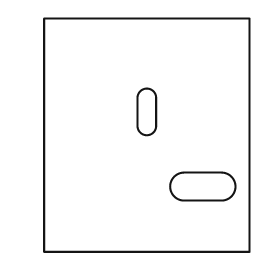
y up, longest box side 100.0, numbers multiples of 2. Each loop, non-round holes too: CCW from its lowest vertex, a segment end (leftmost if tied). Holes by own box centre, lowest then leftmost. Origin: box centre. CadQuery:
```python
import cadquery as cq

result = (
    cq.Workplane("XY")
    .moveTo(-44.0, -50.0)
    .lineTo(44.0, -50.0)
    .lineTo(44.0, 50.0)
    .lineTo(-44.0, 50.0)
    .close()
    .moveTo(16.0, -28.0)
    .lineTo(32.0, -28.0)
    .threePointArc((38.0, -22.0), (32.0, -16.0))
    .lineTo(16.0, -16.0)
    .threePointArc((10.0, -22.0), (16.0, -28.0))
    .close()
    .moveTo(-4.0, 4.0)
    .threePointArc((0.0, 0.0), (4.0, 4.0))
    .lineTo(4.0, 16.0)
    .threePointArc((0.0, 20.0), (-4.0, 16.0))
    .close()
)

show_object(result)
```